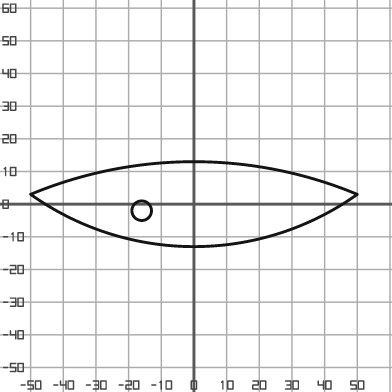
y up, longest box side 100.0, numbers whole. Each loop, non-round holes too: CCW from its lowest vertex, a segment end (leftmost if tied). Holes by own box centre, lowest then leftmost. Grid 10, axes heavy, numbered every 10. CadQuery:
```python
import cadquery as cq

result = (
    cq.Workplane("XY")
    .moveTo(-50.0, 3.0)
    .threePointArc((0.0, -13.0), (50.0, 3.0))
    .threePointArc((0.0, 13.0), (-50.0, 3.0))
    .close()
    .moveTo(-16.0, -2.0)
    .circle(3.0)
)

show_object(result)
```